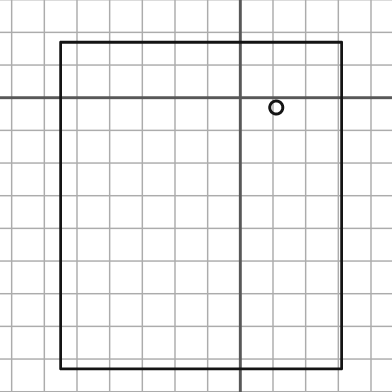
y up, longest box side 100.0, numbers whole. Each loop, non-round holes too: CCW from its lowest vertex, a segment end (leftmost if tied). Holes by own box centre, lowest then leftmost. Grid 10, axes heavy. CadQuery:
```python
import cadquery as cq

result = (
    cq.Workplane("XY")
    .moveTo(-55.0, -83.0)
    .lineTo(31.0, -83.0)
    .lineTo(31.0, 17.0)
    .lineTo(-55.0, 17.0)
    .close()
    .moveTo(11.0, -3.0)
    .circle(2.0)
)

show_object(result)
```